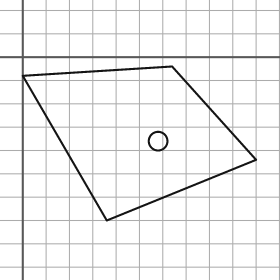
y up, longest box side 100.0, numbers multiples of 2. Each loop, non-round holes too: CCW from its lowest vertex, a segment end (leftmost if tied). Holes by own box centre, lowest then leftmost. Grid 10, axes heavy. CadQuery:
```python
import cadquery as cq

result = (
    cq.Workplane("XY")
    .moveTo(36.0, -70.0)
    .lineTo(100.0, -44.0)
    .lineTo(64.0, -4.0)
    .lineTo(0.0, -8.0)
    .close()
    .moveTo(58.0, -36.0)
    .circle(4.0)
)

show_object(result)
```